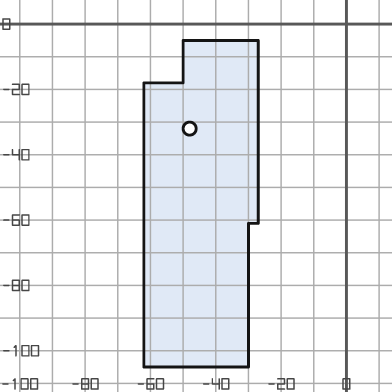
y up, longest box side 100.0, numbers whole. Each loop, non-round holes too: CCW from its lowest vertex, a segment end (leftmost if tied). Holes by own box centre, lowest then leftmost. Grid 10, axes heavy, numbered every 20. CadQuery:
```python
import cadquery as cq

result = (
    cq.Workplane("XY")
    .moveTo(-62.0, -105.0)
    .lineTo(-30.0, -105.0)
    .lineTo(-30.0, -61.0)
    .lineTo(-27.0, -61.0)
    .lineTo(-27.0, -5.0)
    .lineTo(-50.0, -5.0)
    .lineTo(-50.0, -18.0)
    .lineTo(-62.0, -18.0)
    .close()
    .moveTo(-48.0, -32.0)
    .circle(2.0)
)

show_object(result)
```